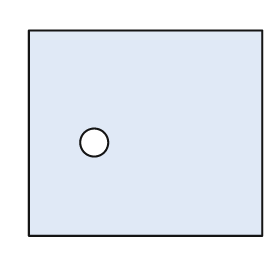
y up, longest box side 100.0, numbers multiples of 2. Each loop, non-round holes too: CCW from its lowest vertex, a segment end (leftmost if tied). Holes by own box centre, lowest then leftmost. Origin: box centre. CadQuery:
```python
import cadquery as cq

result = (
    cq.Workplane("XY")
    .moveTo(-50.0, -44.0)
    .lineTo(50.0, -44.0)
    .lineTo(50.0, 44.0)
    .lineTo(-50.0, 44.0)
    .close()
    .moveTo(-22.0, -4.0)
    .circle(6.0)
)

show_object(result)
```